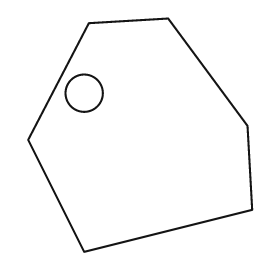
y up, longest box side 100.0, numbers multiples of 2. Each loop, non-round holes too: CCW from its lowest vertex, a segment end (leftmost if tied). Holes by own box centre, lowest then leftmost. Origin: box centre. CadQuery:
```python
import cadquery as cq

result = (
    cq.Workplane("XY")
    .moveTo(-24.0, -50.0)
    .lineTo(48.0, -32.0)
    .lineTo(46.0, 4.0)
    .lineTo(12.0, 50.0)
    .lineTo(-22.0, 48.0)
    .lineTo(-48.0, -2.0)
    .close()
    .moveTo(-24.0, 18.0)
    .circle(8.0)
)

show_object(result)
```